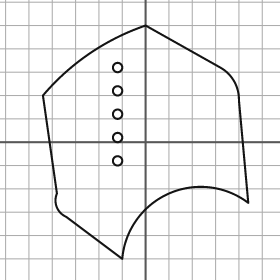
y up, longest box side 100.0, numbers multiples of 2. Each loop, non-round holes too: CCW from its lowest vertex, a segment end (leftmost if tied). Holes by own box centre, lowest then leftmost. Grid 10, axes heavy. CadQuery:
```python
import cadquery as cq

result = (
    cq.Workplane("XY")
    .moveTo(-10.0, -50.0)
    .threePointArc((10.0, -22.0), (44.0, -26.0))
    .lineTo(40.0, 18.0)
    .threePointArc((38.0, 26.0), (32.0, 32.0))
    .lineTo(0.0, 50.0)
    .threePointArc((-24.0, 38.0), (-44.0, 20.0))
    .lineTo(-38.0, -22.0)
    .threePointArc((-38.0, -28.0), (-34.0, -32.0))
    .close()
    .moveTo(-12.0, -8.0)
    .circle(2.0)
    .moveTo(-12.0, 2.0)
    .circle(2.0)
    .moveTo(-12.0, 12.0)
    .circle(2.0)
    .moveTo(-12.0, 22.0)
    .circle(2.0)
    .moveTo(-12.0, 32.0)
    .circle(2.0)
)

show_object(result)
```